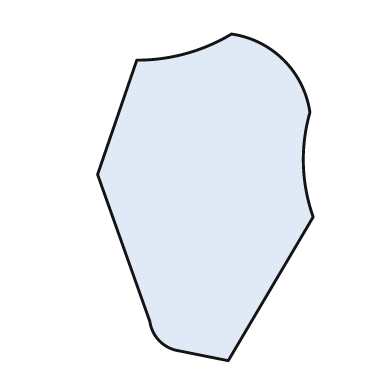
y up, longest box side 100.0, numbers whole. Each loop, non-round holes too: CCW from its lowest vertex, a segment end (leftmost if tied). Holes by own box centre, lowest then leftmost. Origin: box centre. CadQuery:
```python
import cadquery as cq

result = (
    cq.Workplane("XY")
    .moveTo(7.0, -50.0)
    .lineTo(33.0, -6.0)
    .threePointArc((30.0, 10.0), (32.0, 26.0))
    .threePointArc((24.0, 42.0), (8.0, 50.0))
    .threePointArc((-6.0, 44.0), (-21.0, 42.0))
    .lineTo(-33.0, 7.0)
    .lineTo(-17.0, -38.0)
    .threePointArc((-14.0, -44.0), (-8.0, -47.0))
    .close()
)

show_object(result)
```